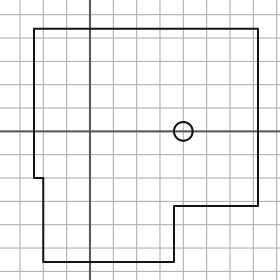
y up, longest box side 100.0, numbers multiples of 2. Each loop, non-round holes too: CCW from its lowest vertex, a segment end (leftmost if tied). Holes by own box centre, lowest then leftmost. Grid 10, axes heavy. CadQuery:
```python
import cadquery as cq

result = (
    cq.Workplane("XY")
    .moveTo(-20.0, -56.0)
    .lineTo(36.0, -56.0)
    .lineTo(36.0, -32.0)
    .lineTo(72.0, -32.0)
    .lineTo(72.0, 44.0)
    .lineTo(-24.0, 44.0)
    .lineTo(-24.0, -20.0)
    .lineTo(-20.0, -20.0)
    .close()
    .moveTo(40.0, 0.0)
    .circle(4.0)
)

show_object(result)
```